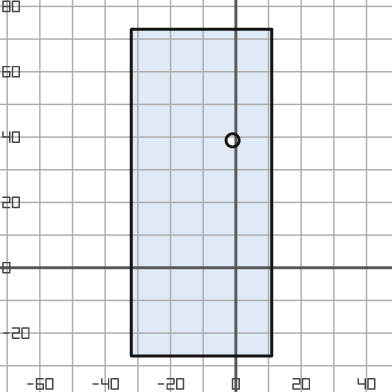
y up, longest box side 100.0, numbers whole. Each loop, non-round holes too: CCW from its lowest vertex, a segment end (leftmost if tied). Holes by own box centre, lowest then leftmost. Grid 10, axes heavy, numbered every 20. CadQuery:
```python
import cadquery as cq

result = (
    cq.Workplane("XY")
    .moveTo(-32.0, -27.0)
    .lineTo(11.0, -27.0)
    .lineTo(11.0, 73.0)
    .lineTo(-32.0, 73.0)
    .close()
    .moveTo(-1.0, 39.0)
    .circle(2.0)
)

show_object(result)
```